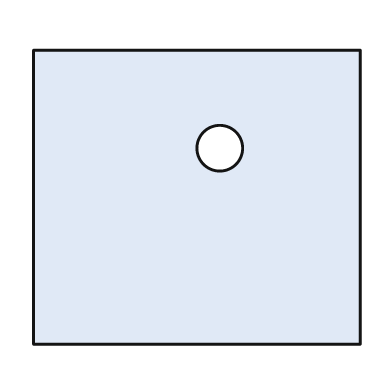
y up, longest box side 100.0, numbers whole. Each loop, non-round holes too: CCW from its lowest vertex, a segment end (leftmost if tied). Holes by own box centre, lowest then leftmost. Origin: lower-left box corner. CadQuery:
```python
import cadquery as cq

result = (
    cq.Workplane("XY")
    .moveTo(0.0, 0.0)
    .lineTo(100.0, 0.0)
    .lineTo(100.0, 90.0)
    .lineTo(0.0, 90.0)
    .close()
    .moveTo(57.0, 60.0)
    .circle(7.0)
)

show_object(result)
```